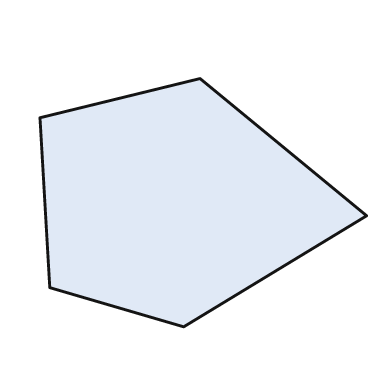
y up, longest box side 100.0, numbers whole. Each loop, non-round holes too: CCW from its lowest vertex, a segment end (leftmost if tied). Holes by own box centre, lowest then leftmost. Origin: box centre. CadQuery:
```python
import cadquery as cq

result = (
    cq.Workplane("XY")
    .moveTo(-6.0, -38.0)
    .lineTo(50.0, -4.0)
    .lineTo(-1.0, 38.0)
    .lineTo(-50.0, 26.0)
    .lineTo(-47.0, -26.0)
    .close()
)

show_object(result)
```